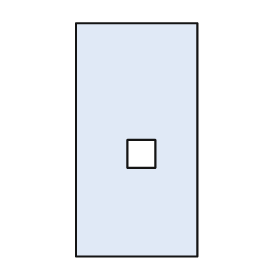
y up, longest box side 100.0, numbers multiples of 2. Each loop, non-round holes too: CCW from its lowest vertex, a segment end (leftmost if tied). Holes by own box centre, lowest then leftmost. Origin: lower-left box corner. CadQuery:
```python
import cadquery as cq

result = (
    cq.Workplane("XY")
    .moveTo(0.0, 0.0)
    .lineTo(52.0, 0.0)
    .lineTo(52.0, 100.0)
    .lineTo(0.0, 100.0)
    .close()
    .moveTo(22.0, 38.0)
    .lineTo(34.0, 38.0)
    .lineTo(34.0, 50.0)
    .lineTo(22.0, 50.0)
    .close()
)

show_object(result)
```